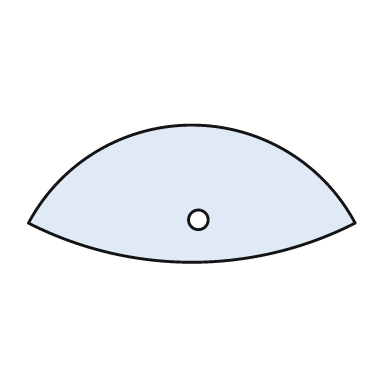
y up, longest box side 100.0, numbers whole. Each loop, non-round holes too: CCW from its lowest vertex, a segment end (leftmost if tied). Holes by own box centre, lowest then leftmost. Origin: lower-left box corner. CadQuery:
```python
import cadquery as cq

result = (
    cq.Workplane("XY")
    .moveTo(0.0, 12.0)
    .threePointArc((50.0, 0.0), (100.0, 12.0))
    .threePointArc((50.0, 42.0), (0.0, 12.0))
    .close()
    .moveTo(52.0, 13.0)
    .circle(3.0)
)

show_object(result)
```